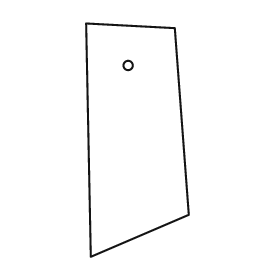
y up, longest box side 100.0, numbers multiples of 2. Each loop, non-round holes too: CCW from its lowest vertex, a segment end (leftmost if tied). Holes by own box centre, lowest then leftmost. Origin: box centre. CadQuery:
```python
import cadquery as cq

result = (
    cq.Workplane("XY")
    .moveTo(-20.0, -50.0)
    .lineTo(22.0, -32.0)
    .lineTo(16.0, 48.0)
    .lineTo(-22.0, 50.0)
    .close()
    .moveTo(-4.0, 32.0)
    .circle(2.0)
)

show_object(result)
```